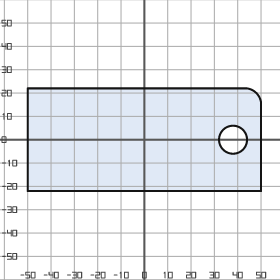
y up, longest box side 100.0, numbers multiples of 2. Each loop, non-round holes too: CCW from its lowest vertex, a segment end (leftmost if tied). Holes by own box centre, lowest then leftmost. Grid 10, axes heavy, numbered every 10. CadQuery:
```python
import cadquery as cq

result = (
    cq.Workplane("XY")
    .moveTo(-50.0, -22.0)
    .lineTo(50.0, -22.0)
    .lineTo(50.0, 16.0)
    .threePointArc((48.0, 20.0), (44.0, 22.0))
    .lineTo(-50.0, 22.0)
    .close()
    .moveTo(38.0, 0.0)
    .circle(6.0)
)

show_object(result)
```